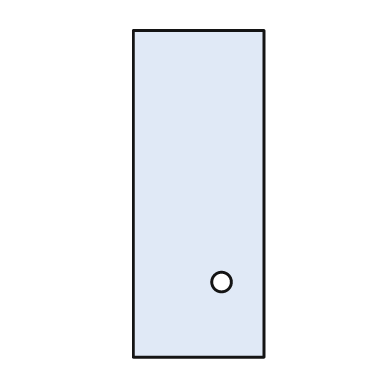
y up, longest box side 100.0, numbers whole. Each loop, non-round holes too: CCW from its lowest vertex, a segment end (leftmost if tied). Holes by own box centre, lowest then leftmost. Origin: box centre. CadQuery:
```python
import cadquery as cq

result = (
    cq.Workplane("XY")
    .moveTo(-20.0, -50.0)
    .lineTo(20.0, -50.0)
    .lineTo(20.0, 50.0)
    .lineTo(-20.0, 50.0)
    .close()
    .moveTo(7.0, -27.0)
    .circle(3.0)
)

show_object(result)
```